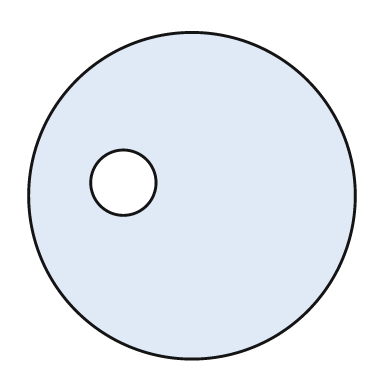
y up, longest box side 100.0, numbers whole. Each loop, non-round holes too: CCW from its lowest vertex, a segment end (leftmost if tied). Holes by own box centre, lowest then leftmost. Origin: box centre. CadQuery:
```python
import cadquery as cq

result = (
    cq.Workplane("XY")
    .moveTo(0.0, 0.0)
    .circle(50.0)
    .moveTo(-21.0, 4.0)
    .circle(10.0)
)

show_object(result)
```